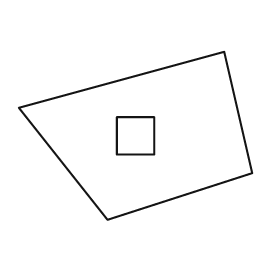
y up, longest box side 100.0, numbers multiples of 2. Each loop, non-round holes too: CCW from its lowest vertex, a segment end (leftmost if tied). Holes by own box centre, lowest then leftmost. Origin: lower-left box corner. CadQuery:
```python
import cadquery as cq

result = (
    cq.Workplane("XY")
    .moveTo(38.0, 0.0)
    .lineTo(100.0, 20.0)
    .lineTo(88.0, 72.0)
    .lineTo(0.0, 48.0)
    .close()
    .moveTo(42.0, 28.0)
    .lineTo(58.0, 28.0)
    .lineTo(58.0, 44.0)
    .lineTo(42.0, 44.0)
    .close()
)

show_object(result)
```